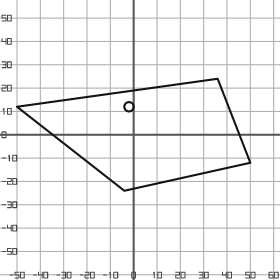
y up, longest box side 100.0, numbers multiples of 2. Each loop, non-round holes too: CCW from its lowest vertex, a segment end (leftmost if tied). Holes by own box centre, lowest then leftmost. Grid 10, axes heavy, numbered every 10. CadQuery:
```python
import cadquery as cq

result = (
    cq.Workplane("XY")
    .moveTo(-4.0, -24.0)
    .lineTo(50.0, -12.0)
    .lineTo(36.0, 24.0)
    .lineTo(-50.0, 12.0)
    .close()
    .moveTo(-2.0, 12.0)
    .circle(2.0)
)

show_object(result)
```